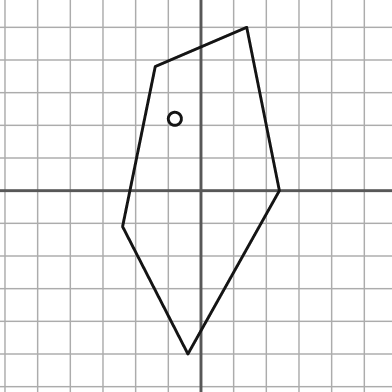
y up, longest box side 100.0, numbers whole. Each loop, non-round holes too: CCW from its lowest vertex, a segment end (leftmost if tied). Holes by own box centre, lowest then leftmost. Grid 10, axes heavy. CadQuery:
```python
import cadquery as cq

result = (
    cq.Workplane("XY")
    .moveTo(-4.0, -50.0)
    .lineTo(24.0, 0.0)
    .lineTo(14.0, 50.0)
    .lineTo(-14.0, 38.0)
    .lineTo(-24.0, -11.0)
    .close()
    .moveTo(-8.0, 22.0)
    .circle(2.0)
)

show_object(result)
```